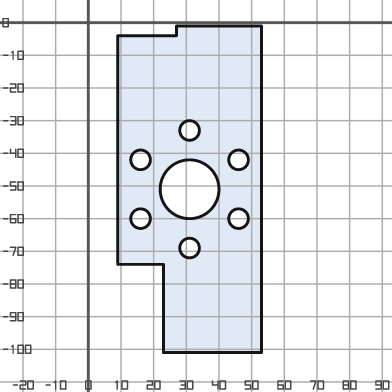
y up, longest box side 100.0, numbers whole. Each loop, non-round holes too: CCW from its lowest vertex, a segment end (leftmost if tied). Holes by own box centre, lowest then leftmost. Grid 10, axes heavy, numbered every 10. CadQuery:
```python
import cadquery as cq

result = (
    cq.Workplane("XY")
    .moveTo(23.0, -101.0)
    .lineTo(53.0, -101.0)
    .lineTo(53.0, -1.0)
    .lineTo(27.0, -1.0)
    .lineTo(27.0, -4.0)
    .lineTo(9.0, -4.0)
    .lineTo(9.0, -74.0)
    .lineTo(23.0, -74.0)
    .close()
    .moveTo(31.0, -69.0)
    .circle(3.0)
    .moveTo(16.0, -60.0)
    .circle(3.0)
    .moveTo(46.0, -60.0)
    .circle(3.0)
    .moveTo(31.0, -51.0)
    .circle(9.0)
    .moveTo(16.0, -42.0)
    .circle(3.0)
    .moveTo(46.0, -42.0)
    .circle(3.0)
    .moveTo(31.0, -33.0)
    .circle(3.0)
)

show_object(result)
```